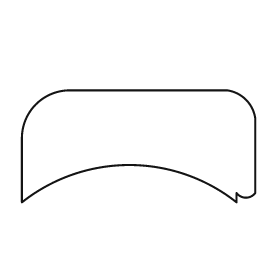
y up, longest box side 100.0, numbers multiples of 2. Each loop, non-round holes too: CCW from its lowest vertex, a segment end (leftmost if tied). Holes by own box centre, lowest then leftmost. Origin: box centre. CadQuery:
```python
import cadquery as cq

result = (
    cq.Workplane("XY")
    .moveTo(-50.0, -24.0)
    .threePointArc((-4.0, -8.0), (42.0, -24.0))
    .lineTo(42.0, -20.0)
    .threePointArc((46.0, -22.0), (50.0, -20.0))
    .lineTo(50.0, 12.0)
    .threePointArc((46.0, 20.0), (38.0, 24.0))
    .lineTo(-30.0, 24.0)
    .threePointArc((-44.0, 18.0), (-50.0, 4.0))
    .close()
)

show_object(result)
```